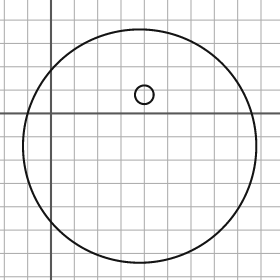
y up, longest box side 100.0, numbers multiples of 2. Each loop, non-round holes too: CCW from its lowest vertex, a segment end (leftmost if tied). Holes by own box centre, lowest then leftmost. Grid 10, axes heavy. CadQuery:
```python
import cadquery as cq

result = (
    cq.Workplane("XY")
    .moveTo(38.0, -14.0)
    .circle(50.0)
    .moveTo(40.0, 8.0)
    .circle(4.0)
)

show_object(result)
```